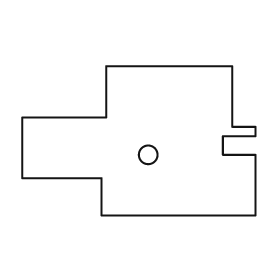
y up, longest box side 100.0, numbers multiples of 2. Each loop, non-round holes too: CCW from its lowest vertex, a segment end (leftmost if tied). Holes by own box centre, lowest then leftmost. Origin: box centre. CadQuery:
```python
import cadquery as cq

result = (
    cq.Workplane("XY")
    .moveTo(-16.0, -32.0)
    .lineTo(50.0, -32.0)
    .lineTo(50.0, -6.0)
    .lineTo(36.0, -6.0)
    .lineTo(36.0, 2.0)
    .lineTo(50.0, 2.0)
    .lineTo(50.0, 6.0)
    .lineTo(40.0, 6.0)
    .lineTo(40.0, 32.0)
    .lineTo(-14.0, 32.0)
    .lineTo(-14.0, 10.0)
    .lineTo(-50.0, 10.0)
    .lineTo(-50.0, -16.0)
    .lineTo(-16.0, -16.0)
    .close()
    .moveTo(4.0, -6.0)
    .circle(4.0)
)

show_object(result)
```